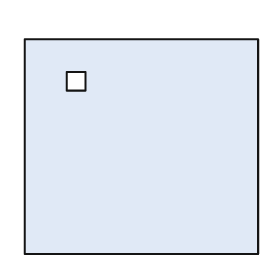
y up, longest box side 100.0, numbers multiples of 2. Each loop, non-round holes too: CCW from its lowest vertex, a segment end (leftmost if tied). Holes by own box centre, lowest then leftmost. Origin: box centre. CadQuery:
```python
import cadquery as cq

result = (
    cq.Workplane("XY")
    .moveTo(-50.0, -46.0)
    .lineTo(50.0, -46.0)
    .lineTo(50.0, 46.0)
    .lineTo(-50.0, 46.0)
    .close()
    .moveTo(-32.0, 24.0)
    .lineTo(-24.0, 24.0)
    .lineTo(-24.0, 32.0)
    .lineTo(-32.0, 32.0)
    .close()
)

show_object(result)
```